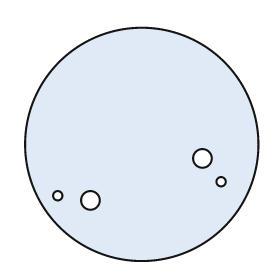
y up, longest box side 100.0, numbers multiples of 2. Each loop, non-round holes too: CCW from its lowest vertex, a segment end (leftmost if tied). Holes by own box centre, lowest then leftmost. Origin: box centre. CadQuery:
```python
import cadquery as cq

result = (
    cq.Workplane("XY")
    .moveTo(0.0, 0.0)
    .circle(50.0)
    .moveTo(-22.0, -24.0)
    .circle(4.0)
    .moveTo(-36.0, -22.0)
    .circle(2.0)
    .moveTo(34.0, -16.0)
    .circle(2.0)
    .moveTo(26.0, -6.0)
    .circle(4.0)
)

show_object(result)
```